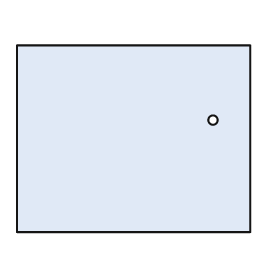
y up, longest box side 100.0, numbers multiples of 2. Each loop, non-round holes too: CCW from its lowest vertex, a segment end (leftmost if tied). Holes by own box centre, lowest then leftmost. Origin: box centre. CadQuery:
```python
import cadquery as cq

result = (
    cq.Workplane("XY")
    .moveTo(-50.0, -40.0)
    .lineTo(50.0, -40.0)
    .lineTo(50.0, 40.0)
    .lineTo(-50.0, 40.0)
    .close()
    .moveTo(34.0, 8.0)
    .circle(2.0)
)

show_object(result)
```